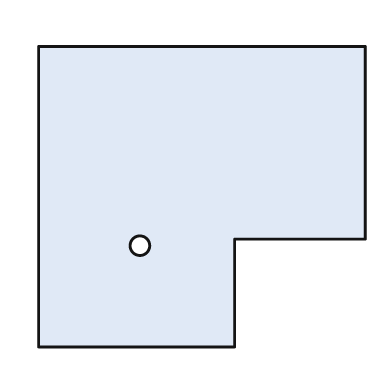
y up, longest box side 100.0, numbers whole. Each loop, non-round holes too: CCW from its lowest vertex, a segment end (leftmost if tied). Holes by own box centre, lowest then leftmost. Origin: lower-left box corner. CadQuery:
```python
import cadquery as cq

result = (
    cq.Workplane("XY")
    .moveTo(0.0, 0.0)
    .lineTo(60.0, 0.0)
    .lineTo(60.0, 33.0)
    .lineTo(100.0, 33.0)
    .lineTo(100.0, 92.0)
    .lineTo(0.0, 92.0)
    .close()
    .moveTo(31.0, 31.0)
    .circle(3.0)
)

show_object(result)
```